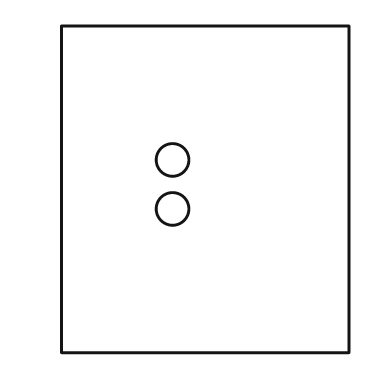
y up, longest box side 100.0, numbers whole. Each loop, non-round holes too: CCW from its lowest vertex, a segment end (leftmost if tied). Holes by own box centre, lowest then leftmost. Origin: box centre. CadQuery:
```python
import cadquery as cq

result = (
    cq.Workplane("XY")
    .moveTo(-44.0, -50.0)
    .lineTo(44.0, -50.0)
    .lineTo(44.0, 50.0)
    .lineTo(-44.0, 50.0)
    .close()
    .moveTo(-10.0, -6.0)
    .circle(5.0)
    .moveTo(-10.0, 9.0)
    .circle(5.0)
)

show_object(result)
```